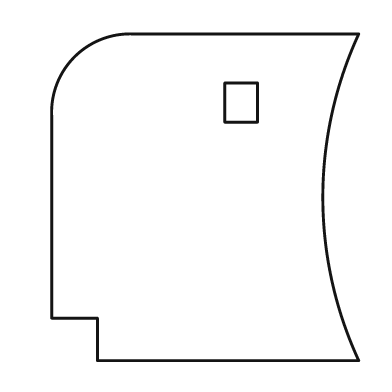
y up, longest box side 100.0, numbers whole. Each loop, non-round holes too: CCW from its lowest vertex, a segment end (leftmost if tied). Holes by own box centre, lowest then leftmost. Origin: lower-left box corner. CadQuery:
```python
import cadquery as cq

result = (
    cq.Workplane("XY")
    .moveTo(14.0, 0.0)
    .lineTo(94.0, 0.0)
    .threePointArc((83.0, 50.0), (94.0, 100.0))
    .lineTo(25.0, 100.0)
    .threePointArc((7.0, 93.0), (0.0, 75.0))
    .lineTo(0.0, 13.0)
    .lineTo(14.0, 13.0)
    .close()
    .moveTo(53.0, 73.0)
    .lineTo(63.0, 73.0)
    .lineTo(63.0, 85.0)
    .lineTo(53.0, 85.0)
    .close()
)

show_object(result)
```